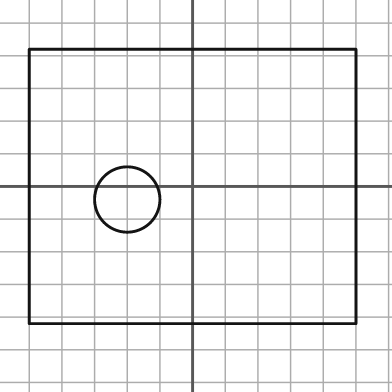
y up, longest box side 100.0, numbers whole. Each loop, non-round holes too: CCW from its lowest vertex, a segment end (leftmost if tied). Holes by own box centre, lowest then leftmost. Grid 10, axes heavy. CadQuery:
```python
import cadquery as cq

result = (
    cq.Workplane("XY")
    .moveTo(-50.0, -42.0)
    .lineTo(50.0, -42.0)
    .lineTo(50.0, 42.0)
    .lineTo(-50.0, 42.0)
    .close()
    .moveTo(-20.0, -4.0)
    .circle(10.0)
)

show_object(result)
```